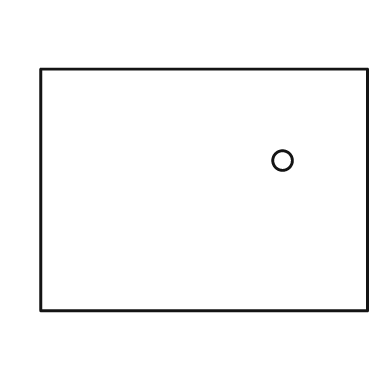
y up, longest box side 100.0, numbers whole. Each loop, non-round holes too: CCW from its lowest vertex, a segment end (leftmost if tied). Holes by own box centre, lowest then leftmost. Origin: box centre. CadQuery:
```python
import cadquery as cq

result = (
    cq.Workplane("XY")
    .moveTo(-50.0, -37.0)
    .lineTo(50.0, -37.0)
    .lineTo(50.0, 37.0)
    .lineTo(-50.0, 37.0)
    .close()
    .moveTo(24.0, 9.0)
    .circle(3.0)
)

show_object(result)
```